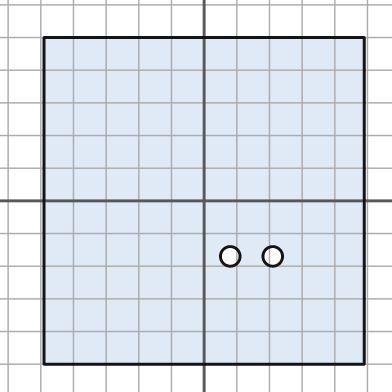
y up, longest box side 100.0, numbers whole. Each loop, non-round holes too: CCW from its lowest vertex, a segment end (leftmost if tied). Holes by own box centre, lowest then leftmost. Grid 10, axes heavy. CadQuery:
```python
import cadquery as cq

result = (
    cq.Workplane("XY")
    .moveTo(-49.0, -50.0)
    .lineTo(49.0, -50.0)
    .lineTo(49.0, 50.0)
    .lineTo(-49.0, 50.0)
    .close()
    .moveTo(8.0, -17.0)
    .circle(3.0)
    .moveTo(21.0, -17.0)
    .circle(3.0)
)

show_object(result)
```